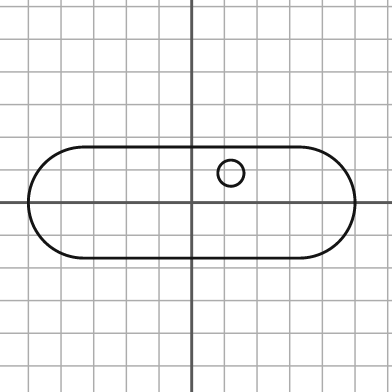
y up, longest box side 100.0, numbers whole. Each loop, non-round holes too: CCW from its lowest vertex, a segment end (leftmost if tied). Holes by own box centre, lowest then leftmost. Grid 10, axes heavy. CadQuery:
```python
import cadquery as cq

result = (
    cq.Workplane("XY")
    .moveTo(-33.0, -17.0)
    .lineTo(33.0, -17.0)
    .threePointArc((50.0, 0.0), (33.0, 17.0))
    .lineTo(-33.0, 17.0)
    .threePointArc((-50.0, 0.0), (-33.0, -17.0))
    .close()
    .moveTo(12.0, 9.0)
    .circle(4.0)
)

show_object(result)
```